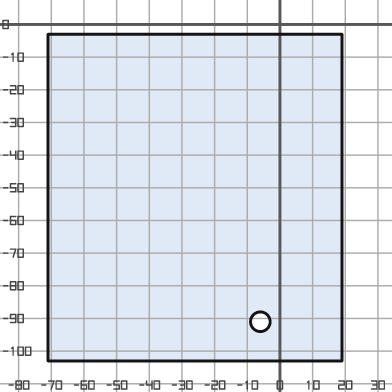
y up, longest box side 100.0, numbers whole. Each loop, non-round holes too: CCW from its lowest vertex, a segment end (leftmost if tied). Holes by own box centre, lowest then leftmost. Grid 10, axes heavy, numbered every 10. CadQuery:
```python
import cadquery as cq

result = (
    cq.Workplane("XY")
    .moveTo(-71.0, -103.0)
    .lineTo(19.0, -103.0)
    .lineTo(19.0, -3.0)
    .lineTo(-71.0, -3.0)
    .close()
    .moveTo(-6.0, -91.0)
    .circle(3.0)
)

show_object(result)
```